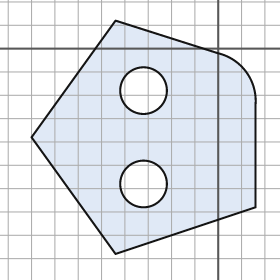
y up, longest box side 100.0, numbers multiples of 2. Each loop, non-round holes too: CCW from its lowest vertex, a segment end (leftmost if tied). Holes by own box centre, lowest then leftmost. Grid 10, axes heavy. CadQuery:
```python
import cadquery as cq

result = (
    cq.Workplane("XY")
    .moveTo(-44.0, -88.0)
    .lineTo(16.0, -68.0)
    .lineTo(16.0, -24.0)
    .threePointArc((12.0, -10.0), (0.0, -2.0))
    .lineTo(-44.0, 12.0)
    .lineTo(-80.0, -38.0)
    .close()
    .moveTo(-32.0, -58.0)
    .circle(10.0)
    .moveTo(-32.0, -18.0)
    .circle(10.0)
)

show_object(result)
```